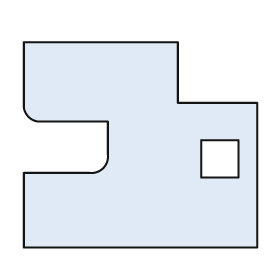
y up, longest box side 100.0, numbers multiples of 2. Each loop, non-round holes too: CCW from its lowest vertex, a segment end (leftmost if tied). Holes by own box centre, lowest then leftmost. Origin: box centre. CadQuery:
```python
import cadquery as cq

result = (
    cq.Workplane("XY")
    .moveTo(-50.0, -44.0)
    .lineTo(50.0, -44.0)
    .lineTo(50.0, 18.0)
    .lineTo(16.0, 18.0)
    .lineTo(16.0, 44.0)
    .lineTo(-50.0, 44.0)
    .lineTo(-50.0, 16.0)
    .threePointArc((-48.0, 12.0), (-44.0, 10.0))
    .lineTo(-14.0, 10.0)
    .lineTo(-14.0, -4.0)
    .threePointArc((-16.0, -10.0), (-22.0, -12.0))
    .lineTo(-50.0, -12.0)
    .close()
    .moveTo(26.0, -14.0)
    .lineTo(42.0, -14.0)
    .lineTo(42.0, 2.0)
    .lineTo(26.0, 2.0)
    .close()
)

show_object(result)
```